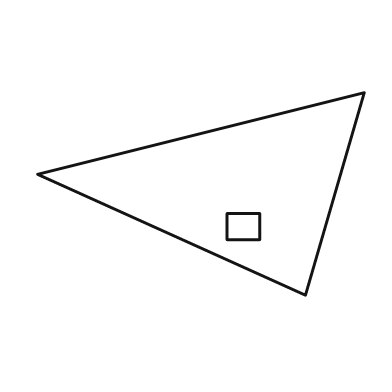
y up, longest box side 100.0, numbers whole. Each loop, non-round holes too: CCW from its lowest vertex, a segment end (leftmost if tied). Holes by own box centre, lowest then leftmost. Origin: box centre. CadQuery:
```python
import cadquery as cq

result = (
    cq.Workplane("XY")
    .moveTo(32.0, -31.0)
    .lineTo(50.0, 31.0)
    .lineTo(-50.0, 6.0)
    .close()
    .moveTo(8.0, -14.0)
    .lineTo(18.0, -14.0)
    .lineTo(18.0, -6.0)
    .lineTo(8.0, -6.0)
    .close()
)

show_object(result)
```